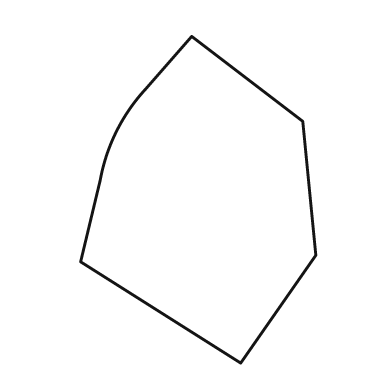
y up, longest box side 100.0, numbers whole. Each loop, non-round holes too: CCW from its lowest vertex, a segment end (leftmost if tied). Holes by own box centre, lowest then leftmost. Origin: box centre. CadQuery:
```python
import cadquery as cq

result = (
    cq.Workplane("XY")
    .moveTo(13.0, -50.0)
    .lineTo(36.0, -17.0)
    .lineTo(32.0, 24.0)
    .lineTo(-2.0, 50.0)
    .lineTo(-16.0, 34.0)
    .threePointArc((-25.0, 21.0), (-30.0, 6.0))
    .lineTo(-36.0, -19.0)
    .close()
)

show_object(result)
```